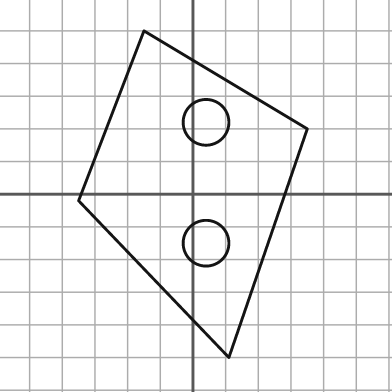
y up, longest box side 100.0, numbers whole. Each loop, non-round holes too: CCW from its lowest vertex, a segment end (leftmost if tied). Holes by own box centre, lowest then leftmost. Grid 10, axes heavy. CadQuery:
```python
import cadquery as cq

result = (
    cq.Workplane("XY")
    .moveTo(11.0, -50.0)
    .lineTo(35.0, 20.0)
    .lineTo(-15.0, 50.0)
    .lineTo(-35.0, -2.0)
    .close()
    .moveTo(4.0, -15.0)
    .circle(7.0)
    .moveTo(4.0, 22.0)
    .circle(7.0)
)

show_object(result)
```